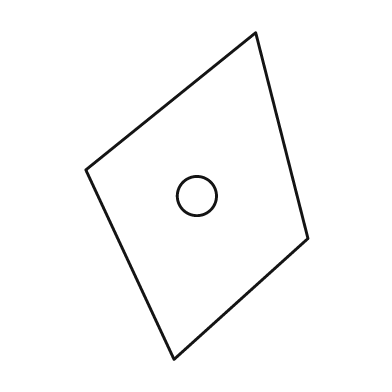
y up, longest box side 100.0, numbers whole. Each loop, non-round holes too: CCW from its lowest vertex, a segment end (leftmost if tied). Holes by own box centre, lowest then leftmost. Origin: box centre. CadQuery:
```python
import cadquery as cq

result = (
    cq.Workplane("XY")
    .moveTo(-7.0, -50.0)
    .lineTo(34.0, -13.0)
    .lineTo(18.0, 50.0)
    .lineTo(-34.0, 8.0)
    .close()
    .moveTo(0.0, 0.0)
    .circle(6.0)
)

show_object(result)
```